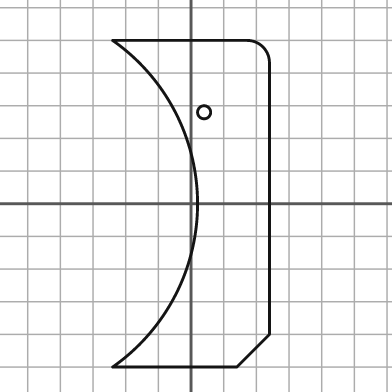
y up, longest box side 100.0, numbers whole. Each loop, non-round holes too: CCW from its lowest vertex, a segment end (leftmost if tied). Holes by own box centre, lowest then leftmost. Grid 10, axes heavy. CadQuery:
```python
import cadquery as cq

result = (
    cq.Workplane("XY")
    .moveTo(-24.0, -50.0)
    .lineTo(14.0, -50.0)
    .lineTo(24.0, -40.0)
    .lineTo(24.0, 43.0)
    .threePointArc((22.0, 48.0), (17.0, 50.0))
    .lineTo(-24.0, 50.0)
    .threePointArc((2.0, 0.0), (-24.0, -50.0))
    .close()
    .moveTo(4.0, 28.0)
    .circle(2.0)
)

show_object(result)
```